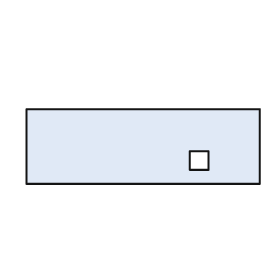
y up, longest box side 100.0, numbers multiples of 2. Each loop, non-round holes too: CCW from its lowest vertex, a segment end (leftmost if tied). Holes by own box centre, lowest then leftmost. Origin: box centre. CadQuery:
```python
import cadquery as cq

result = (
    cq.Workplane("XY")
    .moveTo(-50.0, -16.0)
    .lineTo(50.0, -16.0)
    .lineTo(50.0, 16.0)
    .lineTo(-50.0, 16.0)
    .close()
    .moveTo(20.0, -10.0)
    .lineTo(28.0, -10.0)
    .lineTo(28.0, -2.0)
    .lineTo(20.0, -2.0)
    .close()
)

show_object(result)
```